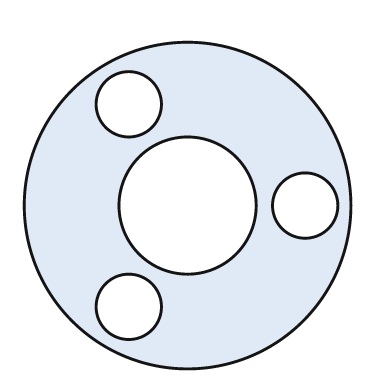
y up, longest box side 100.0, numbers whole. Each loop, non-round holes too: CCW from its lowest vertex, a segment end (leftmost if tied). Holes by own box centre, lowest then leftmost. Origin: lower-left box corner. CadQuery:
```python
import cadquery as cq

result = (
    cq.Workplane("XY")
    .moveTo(50.0, 50.0)
    .circle(50.0)
    .moveTo(32.0, 19.0)
    .circle(10.0)
    .moveTo(50.0, 50.0)
    .circle(21.0)
    .moveTo(86.0, 50.0)
    .circle(10.0)
    .moveTo(32.0, 81.0)
    .circle(10.0)
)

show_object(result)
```